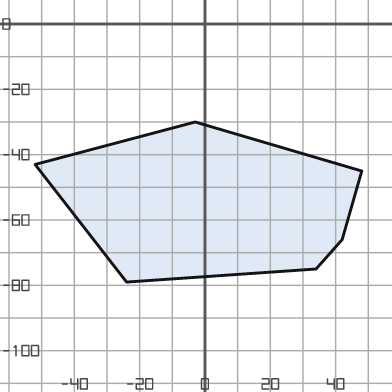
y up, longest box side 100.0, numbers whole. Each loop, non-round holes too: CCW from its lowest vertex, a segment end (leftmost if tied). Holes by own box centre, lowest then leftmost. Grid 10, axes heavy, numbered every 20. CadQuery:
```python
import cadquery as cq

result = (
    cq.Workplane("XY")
    .moveTo(-24.0, -79.0)
    .lineTo(34.0, -75.0)
    .lineTo(42.0, -66.0)
    .lineTo(48.0, -45.0)
    .lineTo(-3.0, -30.0)
    .lineTo(-52.0, -43.0)
    .close()
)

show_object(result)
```